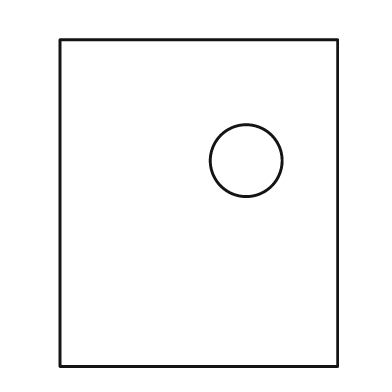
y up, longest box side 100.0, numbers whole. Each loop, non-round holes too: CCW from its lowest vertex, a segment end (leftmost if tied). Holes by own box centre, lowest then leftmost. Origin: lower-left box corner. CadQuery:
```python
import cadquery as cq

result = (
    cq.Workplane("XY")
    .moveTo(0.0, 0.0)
    .lineTo(85.0, 0.0)
    .lineTo(85.0, 100.0)
    .lineTo(0.0, 100.0)
    .close()
    .moveTo(57.0, 63.0)
    .circle(11.0)
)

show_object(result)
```